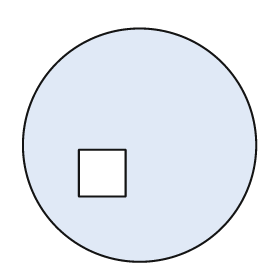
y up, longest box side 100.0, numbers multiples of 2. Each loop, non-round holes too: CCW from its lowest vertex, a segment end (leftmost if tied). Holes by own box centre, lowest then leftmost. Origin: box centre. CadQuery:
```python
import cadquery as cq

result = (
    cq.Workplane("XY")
    .moveTo(0.0, 0.0)
    .circle(50.0)
    .moveTo(-26.0, -22.0)
    .lineTo(-6.0, -22.0)
    .lineTo(-6.0, -2.0)
    .lineTo(-26.0, -2.0)
    .close()
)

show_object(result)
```